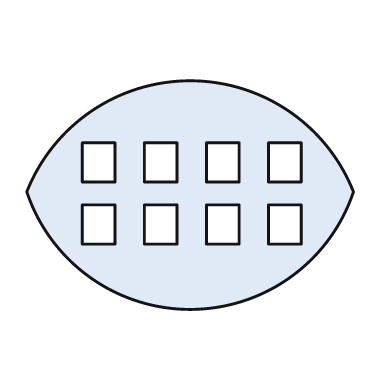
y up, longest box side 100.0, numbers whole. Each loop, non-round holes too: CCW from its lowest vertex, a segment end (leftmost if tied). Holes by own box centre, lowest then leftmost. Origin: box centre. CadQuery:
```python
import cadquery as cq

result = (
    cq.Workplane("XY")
    .moveTo(-50.0, 1.0)
    .threePointArc((0.0, -35.0), (50.0, 1.0))
    .threePointArc((0.0, 35.0), (-50.0, 1.0))
    .close()
    .moveTo(-33.0, -15.0)
    .lineTo(-23.0, -15.0)
    .lineTo(-23.0, -3.0)
    .lineTo(-33.0, -3.0)
    .close()
    .moveTo(-14.0, -15.0)
    .lineTo(-4.0, -15.0)
    .lineTo(-4.0, -3.0)
    .lineTo(-14.0, -3.0)
    .close()
    .moveTo(5.0, -15.0)
    .lineTo(15.0, -15.0)
    .lineTo(15.0, -3.0)
    .lineTo(5.0, -3.0)
    .close()
    .moveTo(24.0, -15.0)
    .lineTo(34.0, -15.0)
    .lineTo(34.0, -3.0)
    .lineTo(24.0, -3.0)
    .close()
    .moveTo(-33.0, 4.0)
    .lineTo(-23.0, 4.0)
    .lineTo(-23.0, 16.0)
    .lineTo(-33.0, 16.0)
    .close()
    .moveTo(-14.0, 4.0)
    .lineTo(-4.0, 4.0)
    .lineTo(-4.0, 16.0)
    .lineTo(-14.0, 16.0)
    .close()
    .moveTo(5.0, 4.0)
    .lineTo(15.0, 4.0)
    .lineTo(15.0, 16.0)
    .lineTo(5.0, 16.0)
    .close()
    .moveTo(24.0, 4.0)
    .lineTo(34.0, 4.0)
    .lineTo(34.0, 16.0)
    .lineTo(24.0, 16.0)
    .close()
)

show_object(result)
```